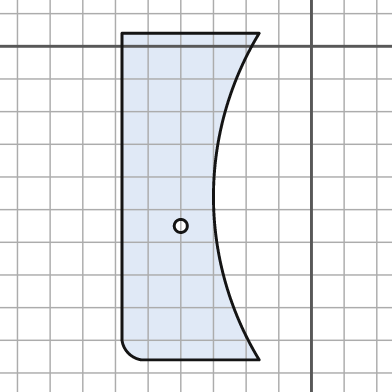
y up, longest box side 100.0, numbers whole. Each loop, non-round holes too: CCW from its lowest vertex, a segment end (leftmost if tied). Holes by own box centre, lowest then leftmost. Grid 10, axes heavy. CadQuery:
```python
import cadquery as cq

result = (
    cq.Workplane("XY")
    .moveTo(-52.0, -96.0)
    .lineTo(-16.0, -96.0)
    .threePointArc((-30.0, -46.0), (-16.0, 4.0))
    .lineTo(-58.0, 4.0)
    .lineTo(-58.0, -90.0)
    .threePointArc((-56.0, -94.0), (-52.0, -96.0))
    .close()
    .moveTo(-40.0, -55.0)
    .circle(2.0)
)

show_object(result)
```